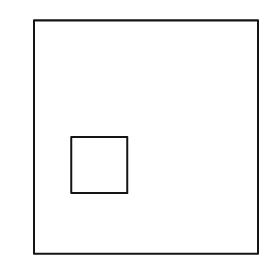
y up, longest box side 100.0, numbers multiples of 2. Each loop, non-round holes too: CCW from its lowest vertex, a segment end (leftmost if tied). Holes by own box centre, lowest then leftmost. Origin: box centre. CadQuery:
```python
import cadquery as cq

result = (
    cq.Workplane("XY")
    .moveTo(-48.0, -50.0)
    .lineTo(48.0, -50.0)
    .lineTo(48.0, 50.0)
    .lineTo(-48.0, 50.0)
    .close()
    .moveTo(-32.0, -24.0)
    .lineTo(-8.0, -24.0)
    .lineTo(-8.0, 0.0)
    .lineTo(-32.0, 0.0)
    .close()
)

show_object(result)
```